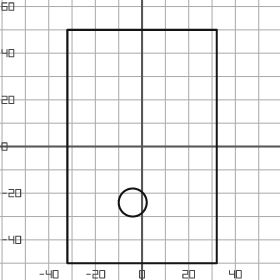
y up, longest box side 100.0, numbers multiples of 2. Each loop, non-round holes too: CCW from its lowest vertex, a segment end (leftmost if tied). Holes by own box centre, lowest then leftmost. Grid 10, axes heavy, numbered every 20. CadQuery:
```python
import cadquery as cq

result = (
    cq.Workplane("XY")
    .moveTo(-32.0, -50.0)
    .lineTo(32.0, -50.0)
    .lineTo(32.0, 50.0)
    .lineTo(-32.0, 50.0)
    .close()
    .moveTo(-4.0, -24.0)
    .circle(6.0)
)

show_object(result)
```